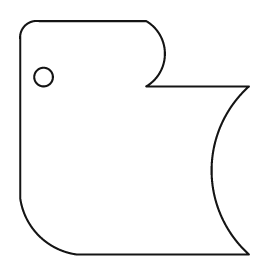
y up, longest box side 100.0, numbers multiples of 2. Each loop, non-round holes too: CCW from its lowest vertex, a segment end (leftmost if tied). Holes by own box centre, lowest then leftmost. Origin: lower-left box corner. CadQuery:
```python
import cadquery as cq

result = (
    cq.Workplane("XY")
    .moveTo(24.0, 0.0)
    .lineTo(98.0, 0.0)
    .threePointArc((82.0, 36.0), (98.0, 72.0))
    .lineTo(54.0, 72.0)
    .threePointArc((62.0, 86.0), (54.0, 100.0))
    .lineTo(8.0, 100.0)
    .threePointArc((2.0, 98.0), (0.0, 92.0))
    .lineTo(0.0, 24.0)
    .threePointArc((8.0, 8.0), (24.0, 0.0))
    .close()
    .moveTo(10.0, 76.0)
    .circle(4.0)
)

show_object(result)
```